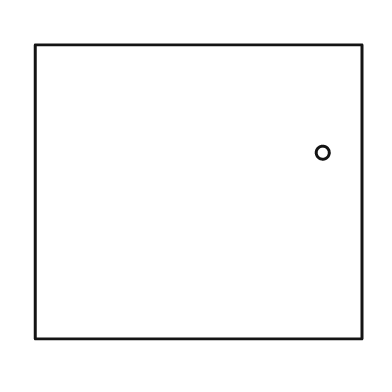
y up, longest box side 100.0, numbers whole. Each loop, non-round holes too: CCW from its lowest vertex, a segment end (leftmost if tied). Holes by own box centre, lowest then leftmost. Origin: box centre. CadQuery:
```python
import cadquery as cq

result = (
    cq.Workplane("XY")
    .moveTo(-50.0, -45.0)
    .lineTo(50.0, -45.0)
    .lineTo(50.0, 45.0)
    .lineTo(-50.0, 45.0)
    .close()
    .moveTo(38.0, 12.0)
    .circle(2.0)
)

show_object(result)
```